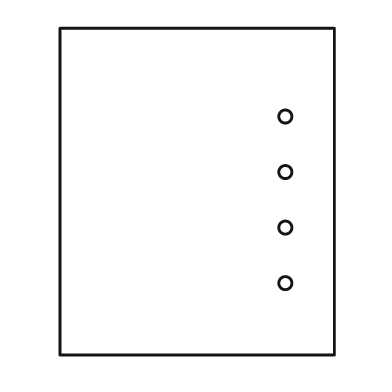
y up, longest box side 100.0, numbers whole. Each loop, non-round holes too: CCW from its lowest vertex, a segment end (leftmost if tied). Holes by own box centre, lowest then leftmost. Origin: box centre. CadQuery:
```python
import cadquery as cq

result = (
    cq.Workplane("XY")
    .moveTo(-42.0, -50.0)
    .lineTo(42.0, -50.0)
    .lineTo(42.0, 50.0)
    .lineTo(-42.0, 50.0)
    .close()
    .moveTo(27.0, -28.0)
    .circle(2.0)
    .moveTo(27.0, -11.0)
    .circle(2.0)
    .moveTo(27.0, 6.0)
    .circle(2.0)
    .moveTo(27.0, 23.0)
    .circle(2.0)
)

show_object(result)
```